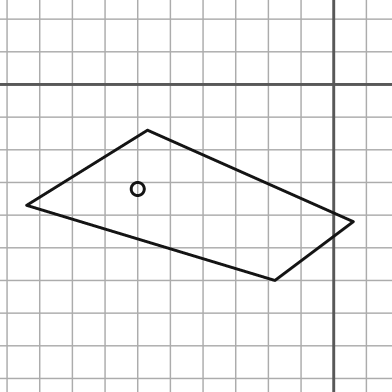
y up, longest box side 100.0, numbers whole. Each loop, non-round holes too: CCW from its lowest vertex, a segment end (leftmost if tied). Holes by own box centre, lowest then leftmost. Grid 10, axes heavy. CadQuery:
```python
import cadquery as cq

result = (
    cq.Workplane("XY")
    .moveTo(-18.0, -60.0)
    .lineTo(6.0, -42.0)
    .lineTo(-57.0, -14.0)
    .lineTo(-94.0, -37.0)
    .close()
    .moveTo(-60.0, -32.0)
    .circle(2.0)
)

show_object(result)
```